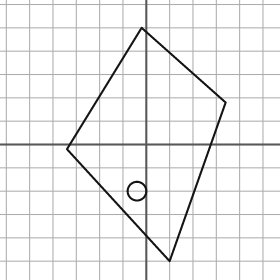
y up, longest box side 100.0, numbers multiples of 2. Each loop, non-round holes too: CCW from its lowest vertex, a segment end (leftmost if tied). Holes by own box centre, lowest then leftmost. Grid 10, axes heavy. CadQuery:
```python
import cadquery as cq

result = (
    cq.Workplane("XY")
    .moveTo(10.0, -50.0)
    .lineTo(34.0, 18.0)
    .lineTo(-2.0, 50.0)
    .lineTo(-34.0, -2.0)
    .close()
    .moveTo(-4.0, -20.0)
    .circle(4.0)
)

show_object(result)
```